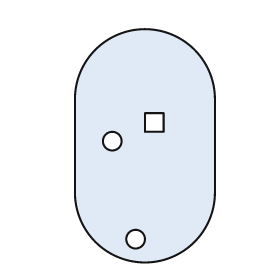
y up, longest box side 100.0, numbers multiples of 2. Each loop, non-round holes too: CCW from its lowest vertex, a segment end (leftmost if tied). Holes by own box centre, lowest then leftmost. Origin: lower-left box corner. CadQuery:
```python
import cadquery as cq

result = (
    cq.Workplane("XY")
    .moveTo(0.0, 30.0)
    .threePointArc((30.0, 0.0), (60.0, 30.0))
    .lineTo(60.0, 70.0)
    .threePointArc((30.0, 100.0), (0.0, 70.0))
    .close()
    .moveTo(26.0, 10.0)
    .circle(4.0)
    .moveTo(16.0, 52.0)
    .circle(4.0)
    .moveTo(30.0, 56.0)
    .lineTo(38.0, 56.0)
    .lineTo(38.0, 64.0)
    .lineTo(30.0, 64.0)
    .close()
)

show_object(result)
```